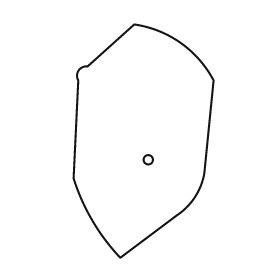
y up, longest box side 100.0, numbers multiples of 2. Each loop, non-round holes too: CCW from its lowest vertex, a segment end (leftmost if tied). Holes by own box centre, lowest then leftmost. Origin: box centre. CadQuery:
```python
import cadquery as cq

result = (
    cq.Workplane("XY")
    .moveTo(-10.0, -50.0)
    .lineTo(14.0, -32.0)
    .threePointArc((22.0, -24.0), (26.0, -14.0))
    .lineTo(30.0, 26.0)
    .threePointArc((16.0, 42.0), (-4.0, 50.0))
    .lineTo(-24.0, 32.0)
    .threePointArc((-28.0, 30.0), (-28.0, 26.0))
    .lineTo(-30.0, -16.0)
    .threePointArc((-22.0, -34.0), (-10.0, -50.0))
    .close()
    .moveTo(2.0, -8.0)
    .circle(2.0)
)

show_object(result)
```